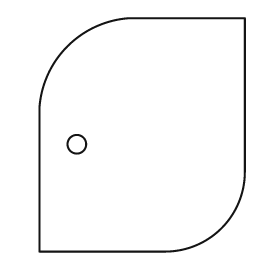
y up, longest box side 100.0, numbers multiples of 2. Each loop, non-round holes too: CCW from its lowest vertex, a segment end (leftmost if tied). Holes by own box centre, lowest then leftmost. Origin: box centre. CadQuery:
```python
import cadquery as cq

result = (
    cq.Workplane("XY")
    .moveTo(-44.0, -50.0)
    .lineTo(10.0, -50.0)
    .threePointArc((34.0, -40.0), (44.0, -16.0))
    .lineTo(44.0, 50.0)
    .lineTo(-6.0, 50.0)
    .threePointArc((-32.0, 38.0), (-44.0, 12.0))
    .close()
    .moveTo(-28.0, -4.0)
    .circle(4.0)
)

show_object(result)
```